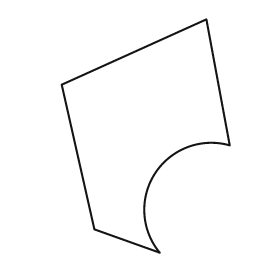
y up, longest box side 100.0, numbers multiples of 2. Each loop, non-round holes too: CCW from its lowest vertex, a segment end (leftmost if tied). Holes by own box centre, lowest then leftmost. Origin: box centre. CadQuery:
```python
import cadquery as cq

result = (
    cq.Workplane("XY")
    .moveTo(6.0, -50.0)
    .threePointArc((4.0, -16.0), (36.0, -4.0))
    .lineTo(26.0, 50.0)
    .lineTo(-36.0, 22.0)
    .lineTo(-22.0, -40.0)
    .close()
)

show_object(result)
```